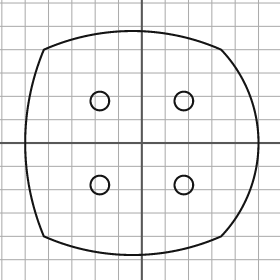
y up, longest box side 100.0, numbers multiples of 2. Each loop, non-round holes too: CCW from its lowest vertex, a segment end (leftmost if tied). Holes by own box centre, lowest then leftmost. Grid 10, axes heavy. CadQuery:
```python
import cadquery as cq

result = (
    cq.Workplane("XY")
    .moveTo(-42.0, -40.0)
    .threePointArc((-4.0, -48.0), (34.0, -40.0))
    .threePointArc((50.0, 0.0), (34.0, 40.0))
    .threePointArc((-4.0, 48.0), (-42.0, 40.0))
    .threePointArc((-50.0, 0.0), (-42.0, -40.0))
    .close()
    .moveTo(-18.0, -18.0)
    .circle(4.0)
    .moveTo(18.0, -18.0)
    .circle(4.0)
    .moveTo(-18.0, 18.0)
    .circle(4.0)
    .moveTo(18.0, 18.0)
    .circle(4.0)
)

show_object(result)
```